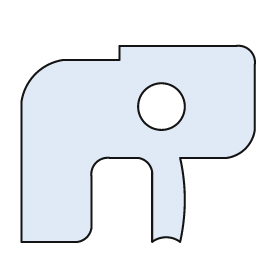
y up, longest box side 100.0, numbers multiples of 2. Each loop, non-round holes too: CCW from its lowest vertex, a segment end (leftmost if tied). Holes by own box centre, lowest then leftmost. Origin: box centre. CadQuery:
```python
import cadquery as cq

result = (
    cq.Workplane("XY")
    .moveTo(-50.0, -42.0)
    .lineTo(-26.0, -42.0)
    .threePointArc((-22.0, -40.0), (-20.0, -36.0))
    .lineTo(-20.0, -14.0)
    .threePointArc((-18.0, -8.0), (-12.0, -6.0))
    .lineTo(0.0, -6.0)
    .threePointArc((4.0, -8.0), (6.0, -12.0))
    .lineTo(6.0, -42.0)
    .threePointArc((12.0, -40.0), (18.0, -42.0))
    .threePointArc((20.0, -24.0), (18.0, -6.0))
    .lineTo(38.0, -6.0)
    .threePointArc((46.0, -2.0), (50.0, 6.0))
    .lineTo(50.0, 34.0)
    .threePointArc((48.0, 40.0), (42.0, 42.0))
    .lineTo(-8.0, 42.0)
    .lineTo(-8.0, 36.0)
    .lineTo(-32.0, 36.0)
    .threePointArc((-44.0, 30.0), (-50.0, 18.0))
    .close()
    .moveTo(10.0, 16.0)
    .circle(10.0)
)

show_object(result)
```